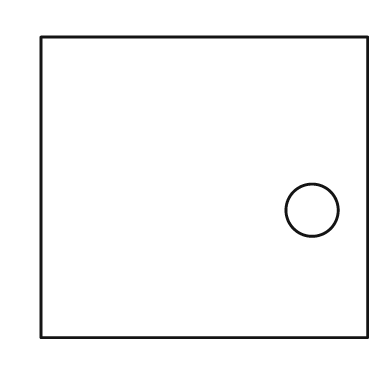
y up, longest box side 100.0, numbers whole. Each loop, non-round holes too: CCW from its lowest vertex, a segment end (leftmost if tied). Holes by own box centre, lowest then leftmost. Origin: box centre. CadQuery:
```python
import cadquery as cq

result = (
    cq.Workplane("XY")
    .moveTo(-50.0, -46.0)
    .lineTo(50.0, -46.0)
    .lineTo(50.0, 46.0)
    .lineTo(-50.0, 46.0)
    .close()
    .moveTo(33.0, -7.0)
    .circle(8.0)
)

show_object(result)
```